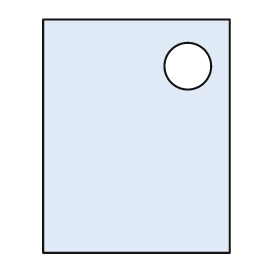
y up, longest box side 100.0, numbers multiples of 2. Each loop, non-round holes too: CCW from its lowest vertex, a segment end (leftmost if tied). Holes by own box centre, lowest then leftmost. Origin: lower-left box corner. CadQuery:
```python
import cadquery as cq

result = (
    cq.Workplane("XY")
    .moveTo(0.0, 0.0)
    .lineTo(80.0, 0.0)
    .lineTo(80.0, 100.0)
    .lineTo(0.0, 100.0)
    .close()
    .moveTo(62.0, 80.0)
    .circle(10.0)
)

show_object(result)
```